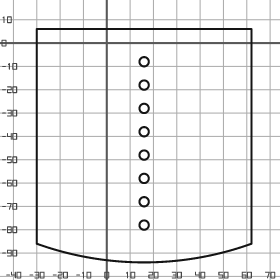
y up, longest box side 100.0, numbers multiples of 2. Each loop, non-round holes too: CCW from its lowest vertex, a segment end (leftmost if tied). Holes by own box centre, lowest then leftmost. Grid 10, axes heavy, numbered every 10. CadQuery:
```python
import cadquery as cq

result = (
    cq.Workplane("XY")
    .moveTo(-30.0, -86.0)
    .threePointArc((16.0, -94.0), (62.0, -86.0))
    .lineTo(62.0, 6.0)
    .lineTo(-30.0, 6.0)
    .close()
    .moveTo(16.0, -78.0)
    .circle(2.0)
    .moveTo(16.0, -68.0)
    .circle(2.0)
    .moveTo(16.0, -58.0)
    .circle(2.0)
    .moveTo(16.0, -48.0)
    .circle(2.0)
    .moveTo(16.0, -38.0)
    .circle(2.0)
    .moveTo(16.0, -28.0)
    .circle(2.0)
    .moveTo(16.0, -18.0)
    .circle(2.0)
    .moveTo(16.0, -8.0)
    .circle(2.0)
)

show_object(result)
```